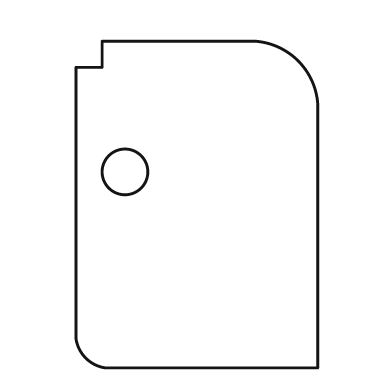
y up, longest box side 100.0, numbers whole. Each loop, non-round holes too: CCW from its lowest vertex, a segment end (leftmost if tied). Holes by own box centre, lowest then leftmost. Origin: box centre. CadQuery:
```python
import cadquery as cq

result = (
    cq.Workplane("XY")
    .moveTo(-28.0, -50.0)
    .lineTo(37.0, -50.0)
    .lineTo(37.0, 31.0)
    .threePointArc((31.0, 44.0), (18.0, 50.0))
    .lineTo(-29.0, 50.0)
    .lineTo(-29.0, 42.0)
    .lineTo(-37.0, 42.0)
    .lineTo(-37.0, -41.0)
    .threePointArc((-34.0, -47.0), (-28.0, -50.0))
    .close()
    .moveTo(-22.0, 10.0)
    .circle(7.0)
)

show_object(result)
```